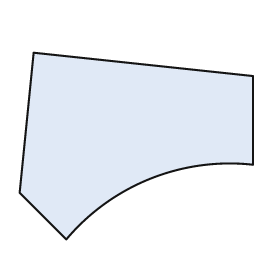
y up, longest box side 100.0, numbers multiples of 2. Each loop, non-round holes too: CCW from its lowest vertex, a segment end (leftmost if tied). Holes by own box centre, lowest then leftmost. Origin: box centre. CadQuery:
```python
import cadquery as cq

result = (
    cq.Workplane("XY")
    .moveTo(-30.0, -40.0)
    .threePointArc((6.0, -14.0), (50.0, -8.0))
    .lineTo(50.0, 30.0)
    .lineTo(-44.0, 40.0)
    .lineTo(-50.0, -20.0)
    .close()
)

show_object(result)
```